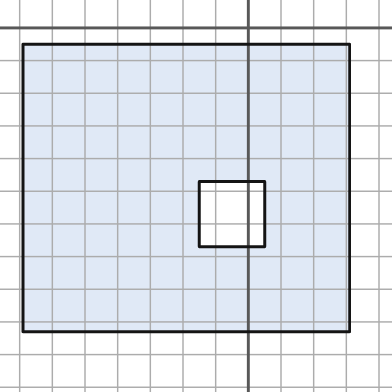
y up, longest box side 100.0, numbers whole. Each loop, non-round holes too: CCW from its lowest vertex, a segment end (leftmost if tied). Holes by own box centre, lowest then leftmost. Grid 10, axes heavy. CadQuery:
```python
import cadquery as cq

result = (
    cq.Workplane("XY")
    .moveTo(-69.0, -93.0)
    .lineTo(31.0, -93.0)
    .lineTo(31.0, -5.0)
    .lineTo(-69.0, -5.0)
    .close()
    .moveTo(-15.0, -67.0)
    .lineTo(5.0, -67.0)
    .lineTo(5.0, -47.0)
    .lineTo(-15.0, -47.0)
    .close()
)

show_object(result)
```